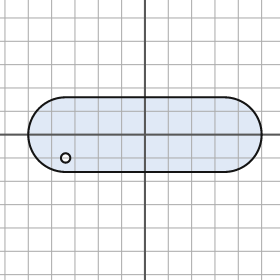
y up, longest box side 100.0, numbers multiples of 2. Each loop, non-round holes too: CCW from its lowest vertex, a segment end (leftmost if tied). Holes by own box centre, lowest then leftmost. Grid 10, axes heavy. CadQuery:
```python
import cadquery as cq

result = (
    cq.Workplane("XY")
    .moveTo(-34.0, -16.0)
    .lineTo(34.0, -16.0)
    .threePointArc((50.0, 0.0), (34.0, 16.0))
    .lineTo(-34.0, 16.0)
    .threePointArc((-50.0, 0.0), (-34.0, -16.0))
    .close()
    .moveTo(-34.0, -10.0)
    .circle(2.0)
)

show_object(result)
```